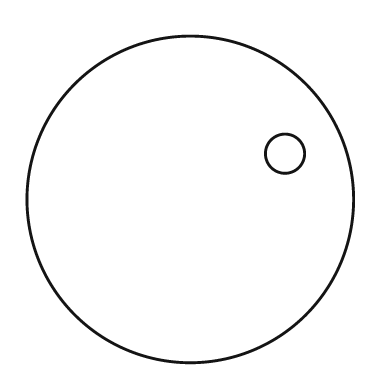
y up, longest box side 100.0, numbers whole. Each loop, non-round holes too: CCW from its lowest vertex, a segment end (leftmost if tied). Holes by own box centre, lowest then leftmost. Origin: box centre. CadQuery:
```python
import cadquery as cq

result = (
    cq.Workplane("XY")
    .moveTo(0.0, 0.0)
    .circle(50.0)
    .moveTo(29.0, 14.0)
    .circle(6.0)
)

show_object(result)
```